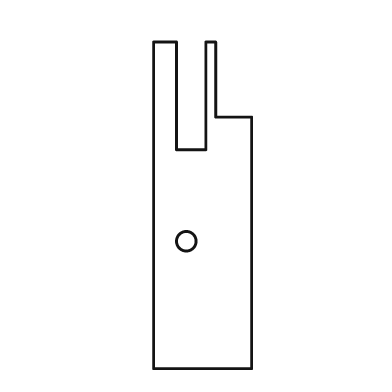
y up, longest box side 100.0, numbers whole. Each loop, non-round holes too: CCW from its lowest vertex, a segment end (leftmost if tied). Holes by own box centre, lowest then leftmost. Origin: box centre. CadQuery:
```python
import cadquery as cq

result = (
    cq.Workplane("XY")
    .moveTo(-15.0, -50.0)
    .lineTo(15.0, -50.0)
    .lineTo(15.0, 27.0)
    .lineTo(4.0, 27.0)
    .lineTo(4.0, 50.0)
    .lineTo(1.0, 50.0)
    .lineTo(1.0, 17.0)
    .lineTo(-8.0, 17.0)
    .lineTo(-8.0, 50.0)
    .lineTo(-15.0, 50.0)
    .close()
    .moveTo(-5.0, -11.0)
    .circle(3.0)
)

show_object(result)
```